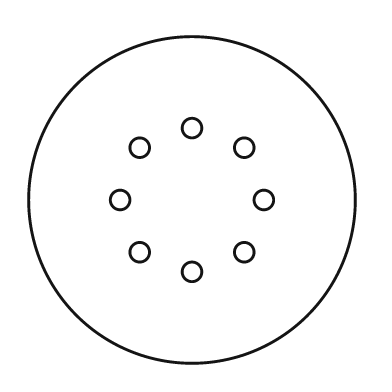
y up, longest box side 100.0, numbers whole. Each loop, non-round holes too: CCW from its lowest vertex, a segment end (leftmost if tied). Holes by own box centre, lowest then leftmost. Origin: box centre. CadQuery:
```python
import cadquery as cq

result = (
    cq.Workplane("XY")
    .moveTo(0.0, 0.0)
    .circle(50.0)
    .moveTo(0.0, -22.0)
    .circle(3.0)
    .moveTo(-16.0, -16.0)
    .circle(3.0)
    .moveTo(16.0, -16.0)
    .circle(3.0)
    .moveTo(-22.0, 0.0)
    .circle(3.0)
    .moveTo(22.0, 0.0)
    .circle(3.0)
    .moveTo(-16.0, 16.0)
    .circle(3.0)
    .moveTo(16.0, 16.0)
    .circle(3.0)
    .moveTo(0.0, 22.0)
    .circle(3.0)
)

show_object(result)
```